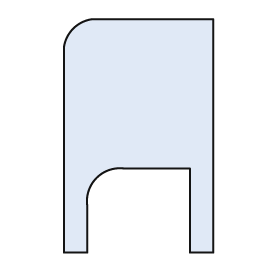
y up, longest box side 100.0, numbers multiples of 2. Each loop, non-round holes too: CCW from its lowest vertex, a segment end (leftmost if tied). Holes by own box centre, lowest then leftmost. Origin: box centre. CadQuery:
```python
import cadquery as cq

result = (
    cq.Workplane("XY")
    .moveTo(-32.0, -50.0)
    .lineTo(-22.0, -50.0)
    .lineTo(-22.0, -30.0)
    .threePointArc((-18.0, -18.0), (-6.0, -14.0))
    .lineTo(22.0, -14.0)
    .lineTo(22.0, -50.0)
    .lineTo(32.0, -50.0)
    .lineTo(32.0, 50.0)
    .lineTo(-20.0, 50.0)
    .threePointArc((-28.0, 46.0), (-32.0, 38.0))
    .close()
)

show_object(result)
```